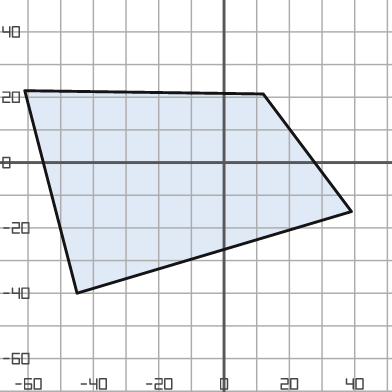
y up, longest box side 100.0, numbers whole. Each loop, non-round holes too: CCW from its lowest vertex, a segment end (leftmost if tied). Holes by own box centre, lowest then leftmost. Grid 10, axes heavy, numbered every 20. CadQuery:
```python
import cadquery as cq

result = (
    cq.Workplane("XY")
    .moveTo(-45.0, -40.0)
    .lineTo(39.0, -15.0)
    .lineTo(12.0, 21.0)
    .lineTo(-61.0, 22.0)
    .close()
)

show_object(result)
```